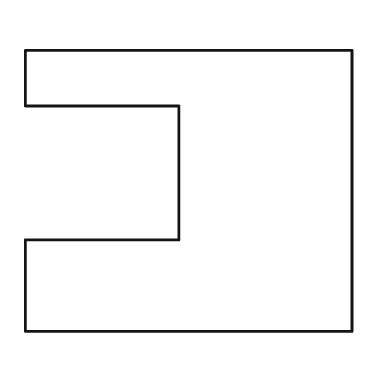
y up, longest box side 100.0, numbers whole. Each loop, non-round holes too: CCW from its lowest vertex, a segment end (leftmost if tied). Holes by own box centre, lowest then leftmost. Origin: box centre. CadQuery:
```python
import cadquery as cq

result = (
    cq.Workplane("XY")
    .moveTo(-50.0, -43.0)
    .lineTo(50.0, -43.0)
    .lineTo(50.0, 43.0)
    .lineTo(-50.0, 43.0)
    .lineTo(-50.0, 26.0)
    .lineTo(-3.0, 26.0)
    .lineTo(-3.0, -15.0)
    .lineTo(-50.0, -15.0)
    .close()
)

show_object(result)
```